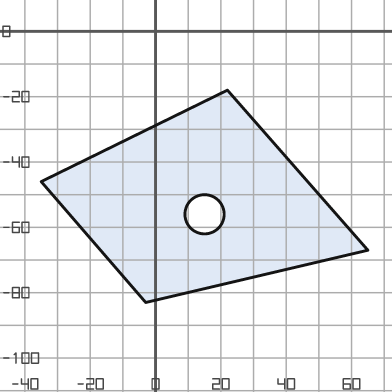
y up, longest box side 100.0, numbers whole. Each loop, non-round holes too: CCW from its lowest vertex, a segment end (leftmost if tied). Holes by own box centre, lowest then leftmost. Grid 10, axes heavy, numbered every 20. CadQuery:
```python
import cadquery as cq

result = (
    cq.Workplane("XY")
    .moveTo(-3.0, -83.0)
    .lineTo(65.0, -67.0)
    .lineTo(22.0, -18.0)
    .lineTo(-35.0, -46.0)
    .close()
    .moveTo(15.0, -56.0)
    .circle(6.0)
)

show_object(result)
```